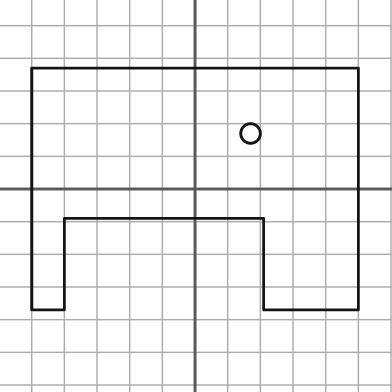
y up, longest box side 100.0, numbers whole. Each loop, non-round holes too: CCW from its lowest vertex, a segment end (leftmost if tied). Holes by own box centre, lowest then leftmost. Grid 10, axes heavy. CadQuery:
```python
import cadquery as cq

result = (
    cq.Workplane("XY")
    .moveTo(-50.0, -37.0)
    .lineTo(-40.0, -37.0)
    .lineTo(-40.0, -9.0)
    .lineTo(21.0, -9.0)
    .lineTo(21.0, -37.0)
    .lineTo(50.0, -37.0)
    .lineTo(50.0, 37.0)
    .lineTo(-50.0, 37.0)
    .close()
    .moveTo(17.0, 17.0)
    .circle(3.0)
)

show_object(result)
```